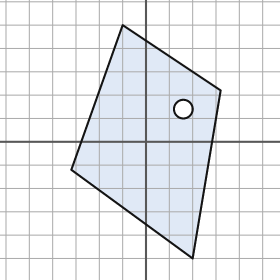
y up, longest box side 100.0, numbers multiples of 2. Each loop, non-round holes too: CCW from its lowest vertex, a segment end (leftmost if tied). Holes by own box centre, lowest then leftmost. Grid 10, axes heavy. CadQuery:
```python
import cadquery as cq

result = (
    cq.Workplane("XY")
    .moveTo(20.0, -50.0)
    .lineTo(32.0, 22.0)
    .lineTo(-10.0, 50.0)
    .lineTo(-32.0, -12.0)
    .close()
    .moveTo(16.0, 14.0)
    .circle(4.0)
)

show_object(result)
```